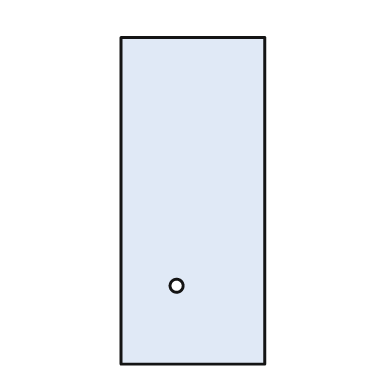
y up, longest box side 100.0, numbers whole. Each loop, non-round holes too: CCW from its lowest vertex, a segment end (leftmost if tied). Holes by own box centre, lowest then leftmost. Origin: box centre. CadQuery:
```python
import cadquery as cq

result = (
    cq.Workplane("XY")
    .moveTo(-22.0, -50.0)
    .lineTo(22.0, -50.0)
    .lineTo(22.0, 50.0)
    .lineTo(-22.0, 50.0)
    .close()
    .moveTo(-5.0, -26.0)
    .circle(2.0)
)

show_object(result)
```